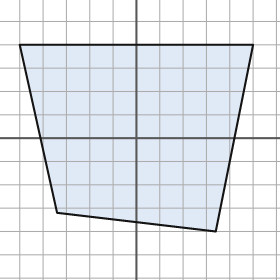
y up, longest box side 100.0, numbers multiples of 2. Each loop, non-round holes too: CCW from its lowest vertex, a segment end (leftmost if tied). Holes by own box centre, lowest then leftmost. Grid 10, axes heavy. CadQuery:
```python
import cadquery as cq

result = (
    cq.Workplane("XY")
    .moveTo(34.0, -40.0)
    .lineTo(50.0, 40.0)
    .lineTo(-50.0, 40.0)
    .lineTo(-34.0, -32.0)
    .close()
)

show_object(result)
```